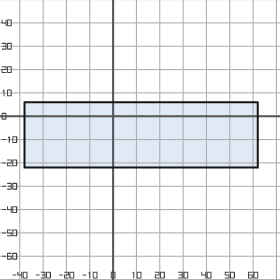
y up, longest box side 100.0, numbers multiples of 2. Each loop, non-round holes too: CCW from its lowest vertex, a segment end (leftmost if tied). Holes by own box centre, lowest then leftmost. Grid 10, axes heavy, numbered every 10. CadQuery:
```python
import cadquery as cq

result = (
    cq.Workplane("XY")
    .moveTo(-38.0, -22.0)
    .lineTo(62.0, -22.0)
    .lineTo(62.0, 6.0)
    .lineTo(-38.0, 6.0)
    .close()
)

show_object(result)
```